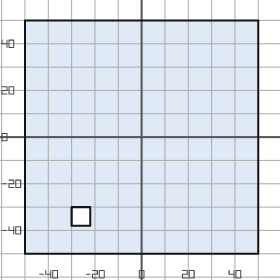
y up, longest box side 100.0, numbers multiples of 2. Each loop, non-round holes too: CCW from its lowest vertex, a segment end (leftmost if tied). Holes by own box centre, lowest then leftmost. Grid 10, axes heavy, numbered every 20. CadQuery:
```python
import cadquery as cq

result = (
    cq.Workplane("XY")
    .moveTo(-50.0, -50.0)
    .lineTo(50.0, -50.0)
    .lineTo(50.0, 50.0)
    .lineTo(-50.0, 50.0)
    .close()
    .moveTo(-30.0, -38.0)
    .lineTo(-22.0, -38.0)
    .lineTo(-22.0, -30.0)
    .lineTo(-30.0, -30.0)
    .close()
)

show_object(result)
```